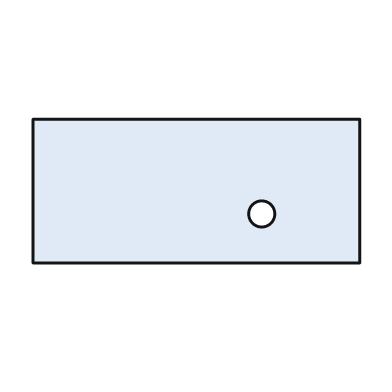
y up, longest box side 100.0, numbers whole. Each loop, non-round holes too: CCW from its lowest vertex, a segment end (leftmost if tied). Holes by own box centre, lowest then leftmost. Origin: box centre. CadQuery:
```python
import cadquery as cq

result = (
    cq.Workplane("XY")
    .moveTo(-50.0, -22.0)
    .lineTo(50.0, -22.0)
    .lineTo(50.0, 22.0)
    .lineTo(-50.0, 22.0)
    .close()
    .moveTo(20.0, -7.0)
    .circle(4.0)
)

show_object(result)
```